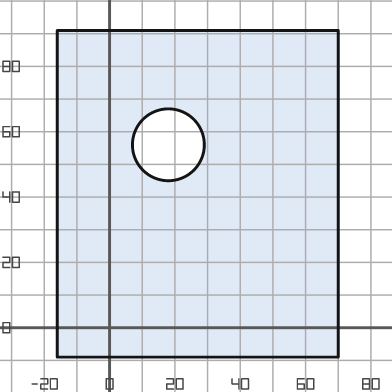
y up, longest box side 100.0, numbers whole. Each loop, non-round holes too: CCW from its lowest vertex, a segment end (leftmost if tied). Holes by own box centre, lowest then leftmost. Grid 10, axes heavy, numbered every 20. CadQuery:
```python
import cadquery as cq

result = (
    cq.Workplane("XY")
    .moveTo(-16.0, -9.0)
    .lineTo(70.0, -9.0)
    .lineTo(70.0, 91.0)
    .lineTo(-16.0, 91.0)
    .close()
    .moveTo(18.0, 56.0)
    .circle(11.0)
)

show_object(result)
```